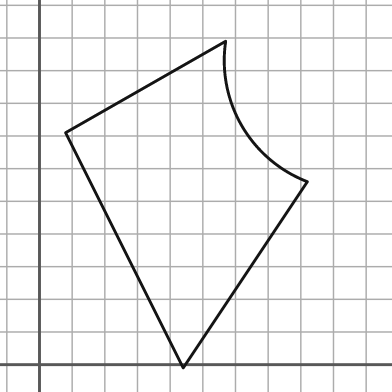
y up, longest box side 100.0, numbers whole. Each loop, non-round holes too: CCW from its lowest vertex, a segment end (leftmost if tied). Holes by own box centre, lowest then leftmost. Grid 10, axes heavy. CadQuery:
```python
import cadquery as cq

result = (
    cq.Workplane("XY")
    .moveTo(44.0, -1.0)
    .lineTo(82.0, 56.0)
    .threePointArc((62.0, 73.0), (57.0, 99.0))
    .lineTo(8.0, 71.0)
    .close()
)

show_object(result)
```